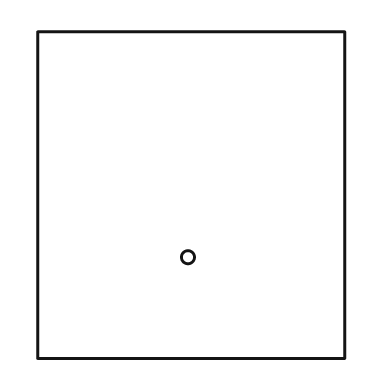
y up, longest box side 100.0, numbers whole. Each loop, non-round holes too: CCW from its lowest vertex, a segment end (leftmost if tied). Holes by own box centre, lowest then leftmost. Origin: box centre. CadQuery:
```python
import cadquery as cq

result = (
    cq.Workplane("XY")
    .moveTo(-47.0, -50.0)
    .lineTo(47.0, -50.0)
    .lineTo(47.0, 50.0)
    .lineTo(-47.0, 50.0)
    .close()
    .moveTo(-1.0, -19.0)
    .circle(2.0)
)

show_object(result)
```